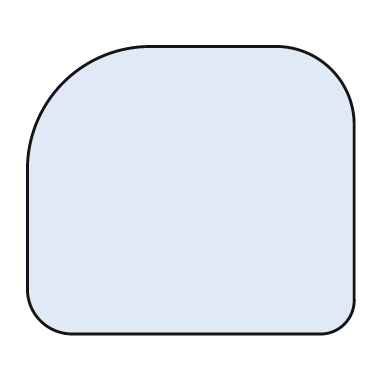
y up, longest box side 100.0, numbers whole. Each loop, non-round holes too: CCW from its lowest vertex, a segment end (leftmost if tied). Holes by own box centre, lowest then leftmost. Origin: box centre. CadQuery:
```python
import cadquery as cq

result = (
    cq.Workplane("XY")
    .moveTo(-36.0, -44.0)
    .lineTo(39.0, -44.0)
    .threePointArc((47.0, -41.0), (50.0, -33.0))
    .lineTo(50.0, 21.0)
    .threePointArc((43.0, 37.0), (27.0, 44.0))
    .lineTo(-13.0, 44.0)
    .threePointArc((-39.0, 33.0), (-50.0, 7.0))
    .lineTo(-50.0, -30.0)
    .threePointArc((-46.0, -40.0), (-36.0, -44.0))
    .close()
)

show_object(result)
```